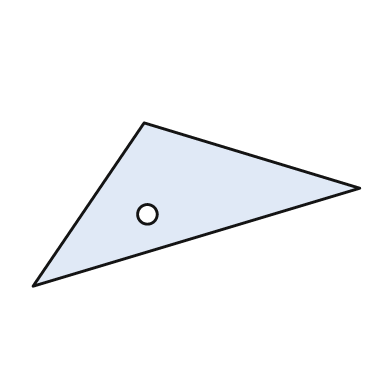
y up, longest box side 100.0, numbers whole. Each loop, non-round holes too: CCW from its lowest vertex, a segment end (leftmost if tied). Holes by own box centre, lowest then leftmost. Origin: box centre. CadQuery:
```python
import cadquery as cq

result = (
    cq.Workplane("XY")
    .moveTo(-50.0, -25.0)
    .lineTo(50.0, 5.0)
    .lineTo(-16.0, 25.0)
    .close()
    .moveTo(-15.0, -3.0)
    .circle(3.0)
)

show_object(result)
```